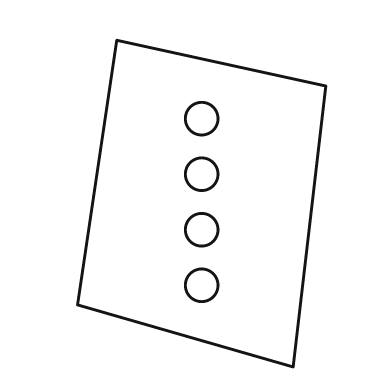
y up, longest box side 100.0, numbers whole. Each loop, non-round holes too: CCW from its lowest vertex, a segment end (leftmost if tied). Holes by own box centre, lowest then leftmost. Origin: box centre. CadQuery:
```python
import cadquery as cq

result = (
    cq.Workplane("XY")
    .moveTo(28.0, -50.0)
    .lineTo(38.0, 36.0)
    .lineTo(-26.0, 50.0)
    .lineTo(-38.0, -31.0)
    .close()
    .moveTo(0.0, -25.0)
    .circle(5.0)
    .moveTo(0.0, -8.0)
    .circle(5.0)
    .moveTo(0.0, 9.0)
    .circle(5.0)
    .moveTo(0.0, 26.0)
    .circle(5.0)
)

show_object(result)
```